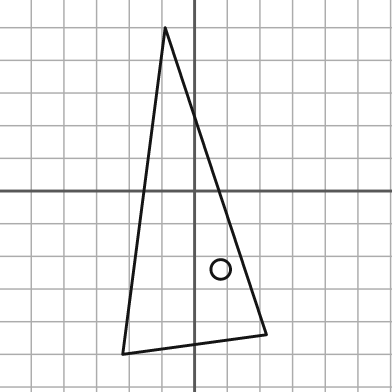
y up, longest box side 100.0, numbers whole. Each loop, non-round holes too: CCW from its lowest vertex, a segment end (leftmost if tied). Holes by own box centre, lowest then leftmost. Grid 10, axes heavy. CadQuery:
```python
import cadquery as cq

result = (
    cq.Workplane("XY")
    .moveTo(-22.0, -50.0)
    .lineTo(22.0, -44.0)
    .lineTo(-9.0, 50.0)
    .close()
    .moveTo(8.0, -24.0)
    .circle(3.0)
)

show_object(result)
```